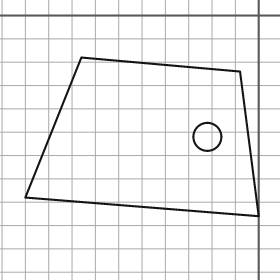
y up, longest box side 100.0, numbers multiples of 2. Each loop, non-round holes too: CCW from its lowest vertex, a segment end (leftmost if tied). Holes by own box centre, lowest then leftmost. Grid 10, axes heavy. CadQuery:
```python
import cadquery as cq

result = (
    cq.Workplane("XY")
    .moveTo(0.0, -86.0)
    .lineTo(-8.0, -24.0)
    .lineTo(-76.0, -18.0)
    .lineTo(-100.0, -78.0)
    .close()
    .moveTo(-22.0, -52.0)
    .circle(6.0)
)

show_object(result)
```